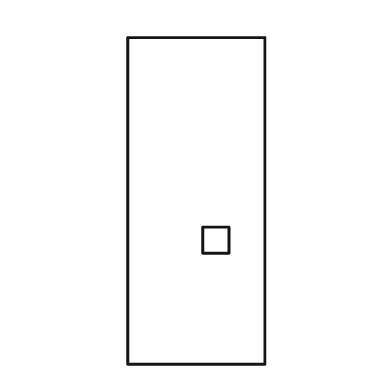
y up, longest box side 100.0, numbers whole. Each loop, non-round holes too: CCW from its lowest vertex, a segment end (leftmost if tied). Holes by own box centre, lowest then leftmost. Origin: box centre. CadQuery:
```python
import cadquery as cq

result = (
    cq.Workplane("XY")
    .moveTo(-21.0, -50.0)
    .lineTo(21.0, -50.0)
    .lineTo(21.0, 50.0)
    .lineTo(-21.0, 50.0)
    .close()
    .moveTo(2.0, -16.0)
    .lineTo(10.0, -16.0)
    .lineTo(10.0, -8.0)
    .lineTo(2.0, -8.0)
    .close()
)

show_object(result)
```